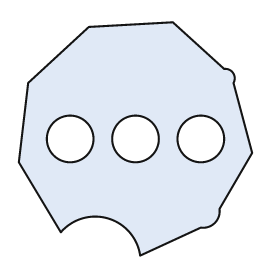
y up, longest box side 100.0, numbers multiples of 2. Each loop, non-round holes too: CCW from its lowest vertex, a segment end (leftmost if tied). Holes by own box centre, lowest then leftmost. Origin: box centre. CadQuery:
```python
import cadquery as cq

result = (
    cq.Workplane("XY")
    .moveTo(2.0, -50.0)
    .lineTo(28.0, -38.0)
    .threePointArc((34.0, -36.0), (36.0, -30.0))
    .lineTo(50.0, -6.0)
    .lineTo(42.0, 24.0)
    .threePointArc((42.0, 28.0), (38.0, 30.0))
    .lineTo(16.0, 50.0)
    .lineTo(-20.0, 48.0)
    .lineTo(-46.0, 24.0)
    .lineTo(-50.0, -10.0)
    .lineTo(-32.0, -40.0)
    .threePointArc((-12.0, -34.0), (2.0, -50.0))
    .close()
    .moveTo(-28.0, 0.0)
    .circle(10.0)
    .moveTo(0.0, 0.0)
    .circle(10.0)
    .moveTo(28.0, 0.0)
    .circle(10.0)
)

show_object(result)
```